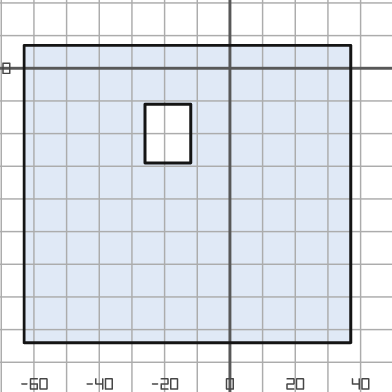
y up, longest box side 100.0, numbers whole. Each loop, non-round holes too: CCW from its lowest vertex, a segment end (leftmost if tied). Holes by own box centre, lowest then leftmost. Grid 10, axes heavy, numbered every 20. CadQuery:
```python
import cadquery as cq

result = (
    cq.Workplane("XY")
    .moveTo(-63.0, -84.0)
    .lineTo(37.0, -84.0)
    .lineTo(37.0, 7.0)
    .lineTo(-63.0, 7.0)
    .close()
    .moveTo(-26.0, -29.0)
    .lineTo(-12.0, -29.0)
    .lineTo(-12.0, -11.0)
    .lineTo(-26.0, -11.0)
    .close()
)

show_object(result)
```